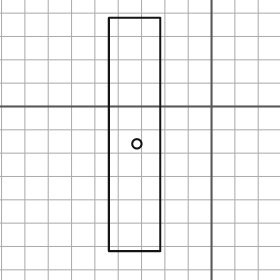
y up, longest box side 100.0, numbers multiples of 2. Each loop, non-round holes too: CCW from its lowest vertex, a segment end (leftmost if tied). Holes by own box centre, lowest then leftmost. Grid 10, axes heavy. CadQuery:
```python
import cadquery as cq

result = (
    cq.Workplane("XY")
    .moveTo(-44.0, -62.0)
    .lineTo(-22.0, -62.0)
    .lineTo(-22.0, 38.0)
    .lineTo(-44.0, 38.0)
    .close()
    .moveTo(-32.0, -16.0)
    .circle(2.0)
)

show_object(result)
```